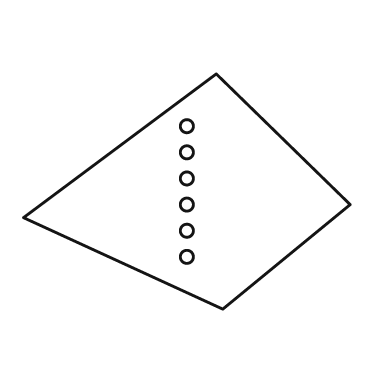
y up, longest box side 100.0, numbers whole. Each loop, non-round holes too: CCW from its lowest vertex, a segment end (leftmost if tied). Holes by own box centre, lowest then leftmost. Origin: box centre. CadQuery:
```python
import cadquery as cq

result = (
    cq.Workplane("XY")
    .moveTo(11.0, -36.0)
    .lineTo(50.0, -4.0)
    .lineTo(9.0, 36.0)
    .lineTo(-50.0, -8.0)
    .close()
    .moveTo(0.0, -20.0)
    .circle(2.0)
    .moveTo(0.0, -12.0)
    .circle(2.0)
    .moveTo(0.0, -4.0)
    .circle(2.0)
    .moveTo(0.0, 4.0)
    .circle(2.0)
    .moveTo(0.0, 12.0)
    .circle(2.0)
    .moveTo(0.0, 20.0)
    .circle(2.0)
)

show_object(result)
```